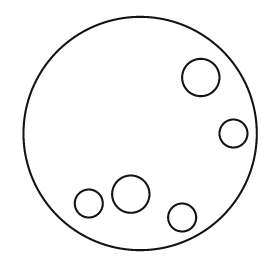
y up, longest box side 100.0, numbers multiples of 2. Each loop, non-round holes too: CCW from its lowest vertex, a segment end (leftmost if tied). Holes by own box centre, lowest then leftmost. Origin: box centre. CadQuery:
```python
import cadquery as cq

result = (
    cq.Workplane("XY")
    .moveTo(0.0, 0.0)
    .circle(50.0)
    .moveTo(18.0, -36.0)
    .circle(6.0)
    .moveTo(-22.0, -30.0)
    .circle(6.0)
    .moveTo(-4.0, -26.0)
    .circle(8.0)
    .moveTo(40.0, 0.0)
    .circle(6.0)
    .moveTo(26.0, 24.0)
    .circle(8.0)
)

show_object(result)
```